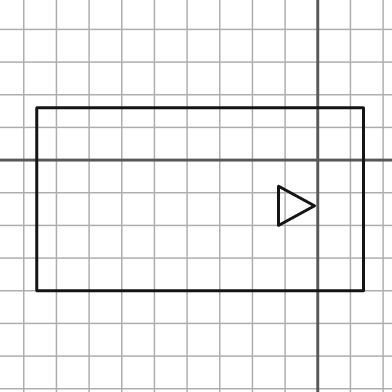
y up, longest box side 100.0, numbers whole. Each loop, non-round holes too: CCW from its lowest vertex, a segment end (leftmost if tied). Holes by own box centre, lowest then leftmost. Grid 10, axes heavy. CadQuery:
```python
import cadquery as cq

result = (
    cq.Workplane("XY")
    .moveTo(-86.0, -40.0)
    .lineTo(14.0, -40.0)
    .lineTo(14.0, 16.0)
    .lineTo(-86.0, 16.0)
    .close()
    .moveTo(-12.0, -20.0)
    .lineTo(-1.0, -14.0)
    .lineTo(-12.0, -8.0)
    .close()
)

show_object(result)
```